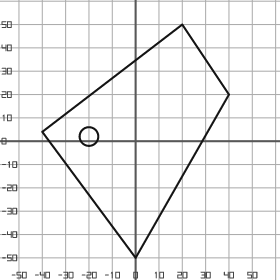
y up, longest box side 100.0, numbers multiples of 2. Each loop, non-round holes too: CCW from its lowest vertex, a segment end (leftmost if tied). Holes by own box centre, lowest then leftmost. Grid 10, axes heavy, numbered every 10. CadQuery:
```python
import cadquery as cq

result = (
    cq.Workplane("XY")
    .moveTo(0.0, -50.0)
    .lineTo(40.0, 20.0)
    .lineTo(20.0, 50.0)
    .lineTo(-40.0, 4.0)
    .close()
    .moveTo(-20.0, 2.0)
    .circle(4.0)
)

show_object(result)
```